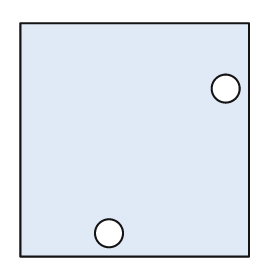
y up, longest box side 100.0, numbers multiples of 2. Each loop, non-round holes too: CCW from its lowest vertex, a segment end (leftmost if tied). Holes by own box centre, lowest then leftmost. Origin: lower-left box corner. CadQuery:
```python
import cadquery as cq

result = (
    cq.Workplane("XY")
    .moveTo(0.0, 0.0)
    .lineTo(98.0, 0.0)
    .lineTo(98.0, 100.0)
    .lineTo(0.0, 100.0)
    .close()
    .moveTo(38.0, 10.0)
    .circle(6.0)
    .moveTo(88.0, 72.0)
    .circle(6.0)
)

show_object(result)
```